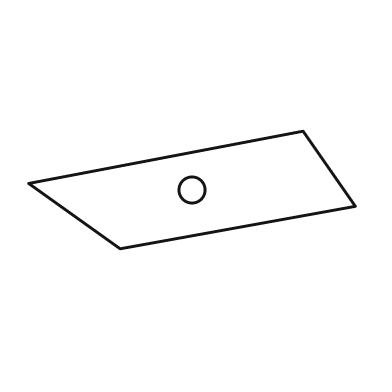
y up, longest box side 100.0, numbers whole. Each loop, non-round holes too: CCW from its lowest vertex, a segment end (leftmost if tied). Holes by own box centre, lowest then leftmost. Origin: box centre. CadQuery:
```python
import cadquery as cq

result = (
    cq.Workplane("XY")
    .moveTo(-22.0, -18.0)
    .lineTo(50.0, -5.0)
    .lineTo(34.0, 18.0)
    .lineTo(-50.0, 2.0)
    .close()
    .moveTo(0.0, 0.0)
    .circle(4.0)
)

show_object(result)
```